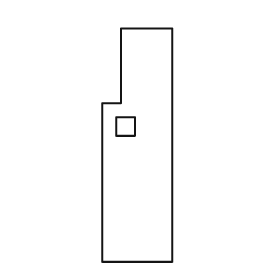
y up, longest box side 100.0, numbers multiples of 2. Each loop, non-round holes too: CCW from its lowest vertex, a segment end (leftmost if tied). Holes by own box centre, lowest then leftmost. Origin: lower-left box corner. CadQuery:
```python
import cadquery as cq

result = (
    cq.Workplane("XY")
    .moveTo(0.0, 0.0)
    .lineTo(30.0, 0.0)
    .lineTo(30.0, 100.0)
    .lineTo(8.0, 100.0)
    .lineTo(8.0, 68.0)
    .lineTo(0.0, 68.0)
    .close()
    .moveTo(6.0, 54.0)
    .lineTo(14.0, 54.0)
    .lineTo(14.0, 62.0)
    .lineTo(6.0, 62.0)
    .close()
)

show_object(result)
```